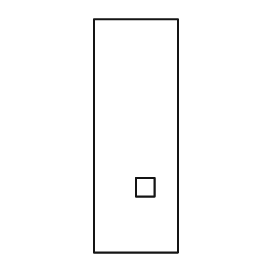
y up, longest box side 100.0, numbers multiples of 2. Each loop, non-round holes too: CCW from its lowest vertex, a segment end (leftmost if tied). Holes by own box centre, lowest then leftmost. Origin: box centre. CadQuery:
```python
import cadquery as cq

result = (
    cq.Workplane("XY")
    .moveTo(-18.0, -50.0)
    .lineTo(18.0, -50.0)
    .lineTo(18.0, 50.0)
    .lineTo(-18.0, 50.0)
    .close()
    .moveTo(0.0, -26.0)
    .lineTo(8.0, -26.0)
    .lineTo(8.0, -18.0)
    .lineTo(0.0, -18.0)
    .close()
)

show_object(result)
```